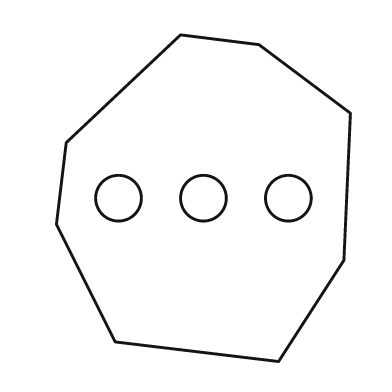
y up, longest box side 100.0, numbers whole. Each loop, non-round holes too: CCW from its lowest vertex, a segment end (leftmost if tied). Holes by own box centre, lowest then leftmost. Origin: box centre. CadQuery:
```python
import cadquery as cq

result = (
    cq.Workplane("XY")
    .moveTo(23.0, -50.0)
    .lineTo(43.0, -19.0)
    .lineTo(45.0, 26.0)
    .lineTo(17.0, 47.0)
    .lineTo(-7.0, 50.0)
    .lineTo(-42.0, 17.0)
    .lineTo(-45.0, -8.0)
    .lineTo(-27.0, -44.0)
    .close()
    .moveTo(-26.0, 0.0)
    .circle(7.0)
    .moveTo(0.0, 0.0)
    .circle(7.0)
    .moveTo(26.0, 0.0)
    .circle(7.0)
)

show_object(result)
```